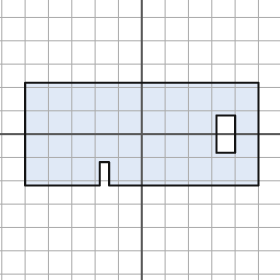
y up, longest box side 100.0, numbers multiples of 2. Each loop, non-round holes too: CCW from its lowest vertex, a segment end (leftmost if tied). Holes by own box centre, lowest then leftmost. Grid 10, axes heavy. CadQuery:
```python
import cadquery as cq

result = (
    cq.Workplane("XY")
    .moveTo(-50.0, -22.0)
    .lineTo(-18.0, -22.0)
    .lineTo(-18.0, -12.0)
    .lineTo(-14.0, -12.0)
    .lineTo(-14.0, -22.0)
    .lineTo(50.0, -22.0)
    .lineTo(50.0, 22.0)
    .lineTo(-50.0, 22.0)
    .close()
    .moveTo(32.0, -8.0)
    .lineTo(40.0, -8.0)
    .lineTo(40.0, 8.0)
    .lineTo(32.0, 8.0)
    .close()
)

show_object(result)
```